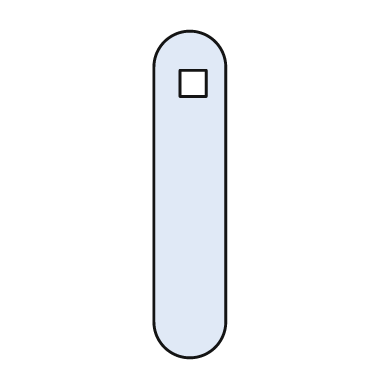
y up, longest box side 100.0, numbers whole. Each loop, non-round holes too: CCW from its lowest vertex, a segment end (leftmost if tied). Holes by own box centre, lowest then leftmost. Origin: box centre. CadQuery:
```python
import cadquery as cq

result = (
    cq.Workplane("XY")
    .moveTo(-11.0, -39.0)
    .threePointArc((0.0, -50.0), (11.0, -39.0))
    .lineTo(11.0, 39.0)
    .threePointArc((0.0, 50.0), (-11.0, 39.0))
    .close()
    .moveTo(-3.0, 30.0)
    .lineTo(5.0, 30.0)
    .lineTo(5.0, 38.0)
    .lineTo(-3.0, 38.0)
    .close()
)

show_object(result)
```